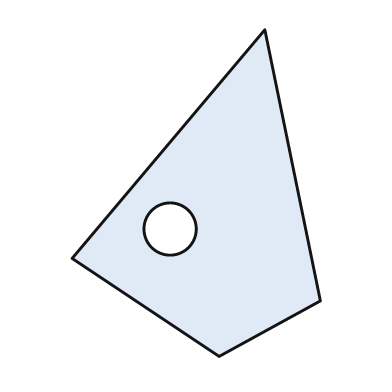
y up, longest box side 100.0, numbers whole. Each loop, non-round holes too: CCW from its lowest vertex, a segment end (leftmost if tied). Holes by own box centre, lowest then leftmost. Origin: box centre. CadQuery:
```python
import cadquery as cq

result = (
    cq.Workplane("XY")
    .moveTo(7.0, -50.0)
    .lineTo(38.0, -33.0)
    .lineTo(21.0, 50.0)
    .lineTo(-38.0, -20.0)
    .close()
    .moveTo(-8.0, -11.0)
    .circle(8.0)
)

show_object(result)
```